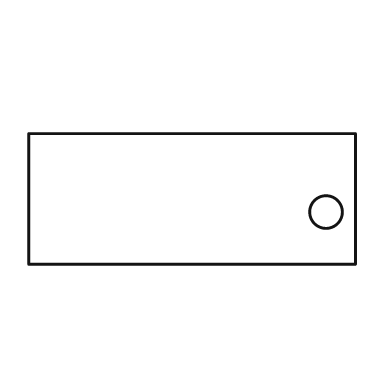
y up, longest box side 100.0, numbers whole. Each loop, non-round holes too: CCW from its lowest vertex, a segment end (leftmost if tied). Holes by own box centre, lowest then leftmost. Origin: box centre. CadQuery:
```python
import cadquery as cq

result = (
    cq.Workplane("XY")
    .moveTo(-50.0, -20.0)
    .lineTo(50.0, -20.0)
    .lineTo(50.0, 20.0)
    .lineTo(-50.0, 20.0)
    .close()
    .moveTo(41.0, -4.0)
    .circle(5.0)
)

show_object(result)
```